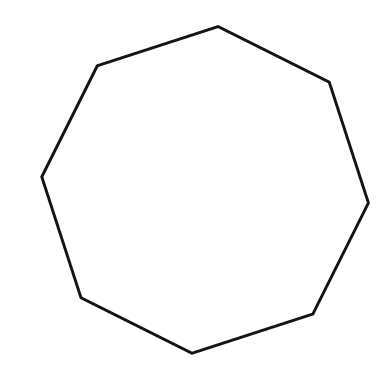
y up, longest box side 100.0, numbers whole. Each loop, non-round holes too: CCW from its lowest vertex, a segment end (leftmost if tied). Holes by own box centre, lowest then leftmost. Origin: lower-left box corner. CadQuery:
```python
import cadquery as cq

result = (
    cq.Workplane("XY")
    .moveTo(46.0, 0.0)
    .lineTo(83.0, 12.0)
    .lineTo(100.0, 46.0)
    .lineTo(88.0, 83.0)
    .lineTo(54.0, 100.0)
    .lineTo(17.0, 88.0)
    .lineTo(0.0, 54.0)
    .lineTo(12.0, 17.0)
    .close()
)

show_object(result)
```